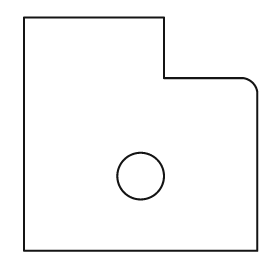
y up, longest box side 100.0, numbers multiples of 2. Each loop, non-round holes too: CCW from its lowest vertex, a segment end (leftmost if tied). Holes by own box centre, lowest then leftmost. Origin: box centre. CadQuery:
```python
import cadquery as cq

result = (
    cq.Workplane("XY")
    .moveTo(-50.0, -50.0)
    .lineTo(50.0, -50.0)
    .lineTo(50.0, 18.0)
    .threePointArc((48.0, 22.0), (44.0, 24.0))
    .lineTo(10.0, 24.0)
    .lineTo(10.0, 50.0)
    .lineTo(-50.0, 50.0)
    .close()
    .moveTo(0.0, -18.0)
    .circle(10.0)
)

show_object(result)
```